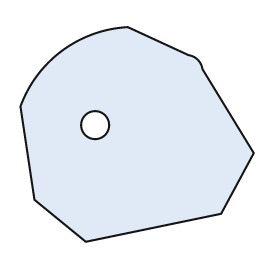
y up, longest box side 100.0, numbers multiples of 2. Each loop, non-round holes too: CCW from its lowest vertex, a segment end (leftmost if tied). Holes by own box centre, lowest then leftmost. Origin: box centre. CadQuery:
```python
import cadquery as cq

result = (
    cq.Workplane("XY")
    .moveTo(-22.0, -46.0)
    .lineTo(36.0, -34.0)
    .lineTo(50.0, -8.0)
    .lineTo(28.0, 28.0)
    .threePointArc((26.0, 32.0), (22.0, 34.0))
    .lineTo(-4.0, 46.0)
    .threePointArc((-32.0, 36.0), (-50.0, 12.0))
    .lineTo(-44.0, -28.0)
    .close()
    .moveTo(-18.0, 4.0)
    .circle(6.0)
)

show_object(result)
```